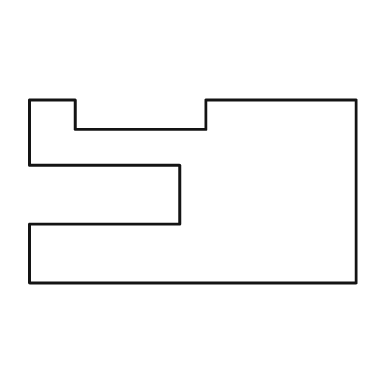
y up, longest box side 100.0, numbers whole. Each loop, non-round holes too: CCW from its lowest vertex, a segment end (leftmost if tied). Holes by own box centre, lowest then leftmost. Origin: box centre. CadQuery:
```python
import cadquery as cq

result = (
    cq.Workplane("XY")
    .moveTo(-50.0, -28.0)
    .lineTo(50.0, -28.0)
    .lineTo(50.0, 28.0)
    .lineTo(4.0, 28.0)
    .lineTo(4.0, 19.0)
    .lineTo(-36.0, 19.0)
    .lineTo(-36.0, 28.0)
    .lineTo(-50.0, 28.0)
    .lineTo(-50.0, 8.0)
    .lineTo(-4.0, 8.0)
    .lineTo(-4.0, -10.0)
    .lineTo(-50.0, -10.0)
    .close()
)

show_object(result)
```